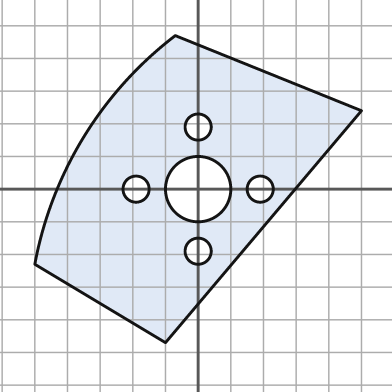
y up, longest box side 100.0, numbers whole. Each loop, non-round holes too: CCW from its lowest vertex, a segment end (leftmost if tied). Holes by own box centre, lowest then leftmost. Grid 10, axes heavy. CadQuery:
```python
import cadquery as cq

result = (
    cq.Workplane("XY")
    .moveTo(-10.0, -47.0)
    .lineTo(50.0, 24.0)
    .lineTo(-7.0, 47.0)
    .threePointArc((-35.0, 16.0), (-50.0, -23.0))
    .close()
    .moveTo(0.0, -19.0)
    .circle(4.0)
    .moveTo(-19.0, 0.0)
    .circle(4.0)
    .moveTo(0.0, 0.0)
    .circle(10.0)
    .moveTo(19.0, 0.0)
    .circle(4.0)
    .moveTo(0.0, 19.0)
    .circle(4.0)
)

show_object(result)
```